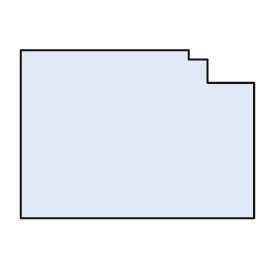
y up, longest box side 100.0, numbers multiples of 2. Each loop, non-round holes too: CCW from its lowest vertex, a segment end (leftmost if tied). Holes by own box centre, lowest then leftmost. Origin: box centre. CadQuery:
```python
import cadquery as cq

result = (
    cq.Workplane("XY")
    .moveTo(-50.0, -36.0)
    .lineTo(50.0, -36.0)
    .lineTo(50.0, 22.0)
    .lineTo(30.0, 22.0)
    .lineTo(30.0, 32.0)
    .lineTo(22.0, 32.0)
    .lineTo(22.0, 36.0)
    .lineTo(-50.0, 36.0)
    .close()
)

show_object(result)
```